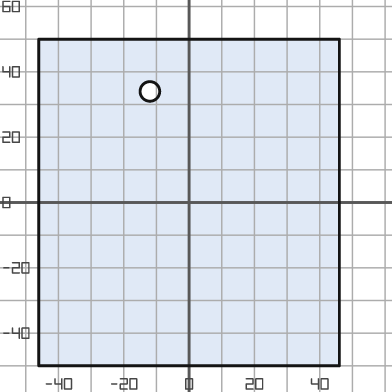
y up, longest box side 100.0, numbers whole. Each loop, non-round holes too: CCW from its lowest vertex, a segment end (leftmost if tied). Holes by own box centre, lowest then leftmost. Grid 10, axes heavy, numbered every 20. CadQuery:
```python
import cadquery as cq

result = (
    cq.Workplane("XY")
    .moveTo(-46.0, -50.0)
    .lineTo(46.0, -50.0)
    .lineTo(46.0, 50.0)
    .lineTo(-46.0, 50.0)
    .close()
    .moveTo(-12.0, 34.0)
    .circle(3.0)
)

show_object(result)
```